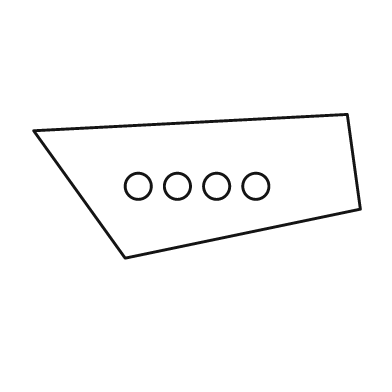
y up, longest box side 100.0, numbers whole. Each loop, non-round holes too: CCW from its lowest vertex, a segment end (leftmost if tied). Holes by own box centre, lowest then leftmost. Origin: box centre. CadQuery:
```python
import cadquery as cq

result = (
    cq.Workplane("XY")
    .moveTo(-22.0, -22.0)
    .lineTo(50.0, -7.0)
    .lineTo(46.0, 22.0)
    .lineTo(-50.0, 17.0)
    .close()
    .moveTo(-18.0, 0.0)
    .circle(4.0)
    .moveTo(-6.0, 0.0)
    .circle(4.0)
    .moveTo(6.0, 0.0)
    .circle(4.0)
    .moveTo(18.0, 0.0)
    .circle(4.0)
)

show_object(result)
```